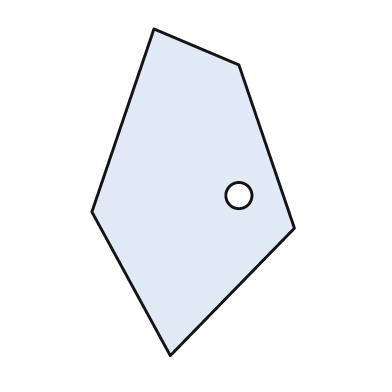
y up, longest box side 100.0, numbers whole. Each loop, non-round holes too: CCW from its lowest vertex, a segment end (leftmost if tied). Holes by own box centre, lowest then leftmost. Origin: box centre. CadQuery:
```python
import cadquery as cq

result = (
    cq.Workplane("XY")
    .moveTo(-7.0, -50.0)
    .lineTo(31.0, -11.0)
    .lineTo(14.0, 39.0)
    .lineTo(-12.0, 50.0)
    .lineTo(-31.0, -6.0)
    .close()
    .moveTo(14.0, -1.0)
    .circle(4.0)
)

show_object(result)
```